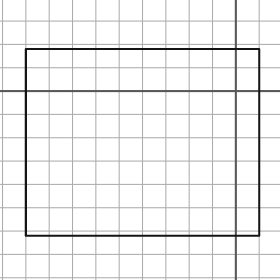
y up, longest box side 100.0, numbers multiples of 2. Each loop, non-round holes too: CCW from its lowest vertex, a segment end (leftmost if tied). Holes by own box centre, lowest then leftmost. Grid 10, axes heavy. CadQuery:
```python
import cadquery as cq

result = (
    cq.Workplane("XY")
    .moveTo(-90.0, -62.0)
    .lineTo(10.0, -62.0)
    .lineTo(10.0, 18.0)
    .lineTo(-90.0, 18.0)
    .close()
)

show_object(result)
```